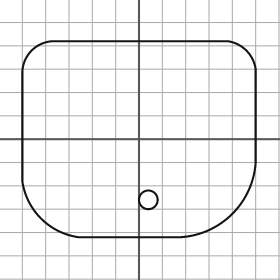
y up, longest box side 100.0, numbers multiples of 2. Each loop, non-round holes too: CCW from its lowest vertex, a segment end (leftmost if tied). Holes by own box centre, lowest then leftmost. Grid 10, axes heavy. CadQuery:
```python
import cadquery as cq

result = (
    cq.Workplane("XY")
    .moveTo(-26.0, -42.0)
    .lineTo(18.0, -42.0)
    .threePointArc((40.0, -32.0), (50.0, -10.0))
    .lineTo(50.0, 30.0)
    .threePointArc((46.0, 38.0), (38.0, 42.0))
    .lineTo(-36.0, 42.0)
    .threePointArc((-46.0, 38.0), (-50.0, 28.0))
    .lineTo(-50.0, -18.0)
    .threePointArc((-42.0, -34.0), (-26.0, -42.0))
    .close()
    .moveTo(4.0, -26.0)
    .circle(4.0)
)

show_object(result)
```